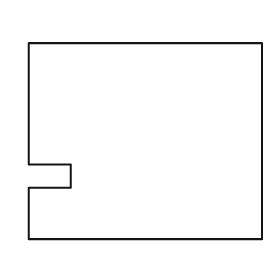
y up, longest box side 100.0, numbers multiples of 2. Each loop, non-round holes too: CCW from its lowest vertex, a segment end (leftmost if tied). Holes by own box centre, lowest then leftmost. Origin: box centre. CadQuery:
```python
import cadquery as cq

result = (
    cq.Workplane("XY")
    .moveTo(-50.0, -42.0)
    .lineTo(50.0, -42.0)
    .lineTo(50.0, 42.0)
    .lineTo(-50.0, 42.0)
    .lineTo(-50.0, -10.0)
    .lineTo(-32.0, -10.0)
    .lineTo(-32.0, -20.0)
    .lineTo(-50.0, -20.0)
    .close()
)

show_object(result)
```